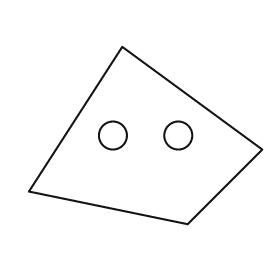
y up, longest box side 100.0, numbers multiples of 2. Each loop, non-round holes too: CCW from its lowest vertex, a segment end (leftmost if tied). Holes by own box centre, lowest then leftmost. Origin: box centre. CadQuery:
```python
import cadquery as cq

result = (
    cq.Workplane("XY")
    .moveTo(18.0, -38.0)
    .lineTo(50.0, -6.0)
    .lineTo(-10.0, 38.0)
    .lineTo(-50.0, -24.0)
    .close()
    .moveTo(-14.0, 0.0)
    .circle(6.0)
    .moveTo(14.0, 0.0)
    .circle(6.0)
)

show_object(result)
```